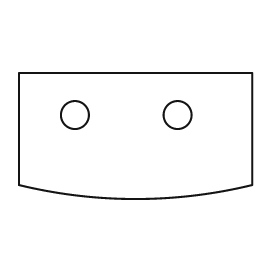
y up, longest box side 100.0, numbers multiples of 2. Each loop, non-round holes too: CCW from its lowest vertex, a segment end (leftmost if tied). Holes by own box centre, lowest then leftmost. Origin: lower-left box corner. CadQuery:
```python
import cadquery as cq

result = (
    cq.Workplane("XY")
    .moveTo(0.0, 6.0)
    .threePointArc((50.0, 0.0), (100.0, 6.0))
    .lineTo(100.0, 54.0)
    .lineTo(0.0, 54.0)
    .close()
    .moveTo(24.0, 36.0)
    .circle(6.0)
    .moveTo(68.0, 36.0)
    .circle(6.0)
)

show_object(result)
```